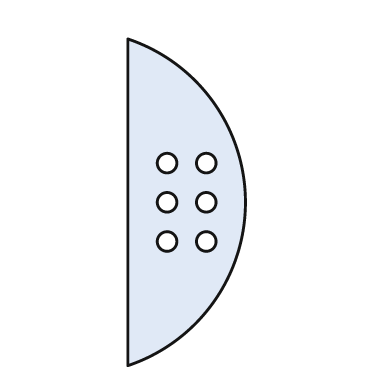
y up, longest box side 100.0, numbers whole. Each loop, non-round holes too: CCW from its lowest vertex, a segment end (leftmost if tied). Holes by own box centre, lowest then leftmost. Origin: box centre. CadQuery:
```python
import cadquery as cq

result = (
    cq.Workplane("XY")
    .moveTo(-18.0, -50.0)
    .threePointArc((18.0, 0.0), (-18.0, 50.0))
    .close()
    .moveTo(-6.0, -12.0)
    .circle(3.0)
    .moveTo(6.0, -12.0)
    .circle(3.0)
    .moveTo(-6.0, 0.0)
    .circle(3.0)
    .moveTo(6.0, 0.0)
    .circle(3.0)
    .moveTo(-6.0, 12.0)
    .circle(3.0)
    .moveTo(6.0, 12.0)
    .circle(3.0)
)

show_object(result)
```